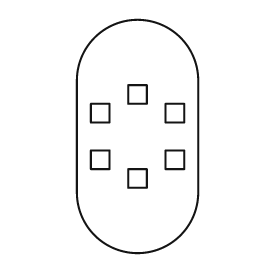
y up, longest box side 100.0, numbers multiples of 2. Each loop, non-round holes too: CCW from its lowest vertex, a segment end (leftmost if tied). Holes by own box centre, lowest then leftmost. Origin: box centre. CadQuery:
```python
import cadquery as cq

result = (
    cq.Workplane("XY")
    .moveTo(-26.0, -24.0)
    .threePointArc((0.0, -50.0), (26.0, -24.0))
    .lineTo(26.0, 24.0)
    .threePointArc((0.0, 50.0), (-26.0, 24.0))
    .close()
    .moveTo(-4.0, -22.0)
    .lineTo(4.0, -22.0)
    .lineTo(4.0, -14.0)
    .lineTo(-4.0, -14.0)
    .close()
    .moveTo(-20.0, -14.0)
    .lineTo(-12.0, -14.0)
    .lineTo(-12.0, -6.0)
    .lineTo(-20.0, -6.0)
    .close()
    .moveTo(12.0, -14.0)
    .lineTo(20.0, -14.0)
    .lineTo(20.0, -6.0)
    .lineTo(12.0, -6.0)
    .close()
    .moveTo(-20.0, 6.0)
    .lineTo(-12.0, 6.0)
    .lineTo(-12.0, 14.0)
    .lineTo(-20.0, 14.0)
    .close()
    .moveTo(12.0, 6.0)
    .lineTo(20.0, 6.0)
    .lineTo(20.0, 14.0)
    .lineTo(12.0, 14.0)
    .close()
    .moveTo(-4.0, 14.0)
    .lineTo(4.0, 14.0)
    .lineTo(4.0, 22.0)
    .lineTo(-4.0, 22.0)
    .close()
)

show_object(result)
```